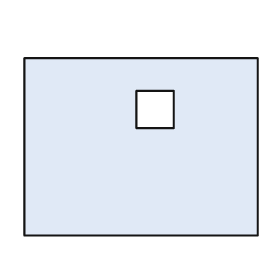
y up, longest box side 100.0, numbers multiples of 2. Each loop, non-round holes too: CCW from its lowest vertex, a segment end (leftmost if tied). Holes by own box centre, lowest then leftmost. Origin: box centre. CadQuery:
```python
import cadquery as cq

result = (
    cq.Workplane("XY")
    .moveTo(-50.0, -38.0)
    .lineTo(50.0, -38.0)
    .lineTo(50.0, 38.0)
    .lineTo(-50.0, 38.0)
    .close()
    .moveTo(-2.0, 8.0)
    .lineTo(14.0, 8.0)
    .lineTo(14.0, 24.0)
    .lineTo(-2.0, 24.0)
    .close()
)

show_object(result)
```